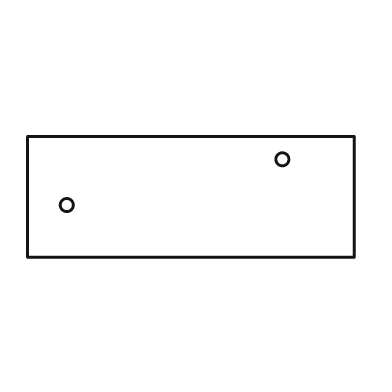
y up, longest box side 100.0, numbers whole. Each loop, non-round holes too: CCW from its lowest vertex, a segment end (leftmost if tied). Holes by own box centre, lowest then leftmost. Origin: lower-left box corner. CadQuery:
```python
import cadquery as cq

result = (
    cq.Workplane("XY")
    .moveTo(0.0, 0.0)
    .lineTo(100.0, 0.0)
    .lineTo(100.0, 37.0)
    .lineTo(0.0, 37.0)
    .close()
    .moveTo(12.0, 16.0)
    .circle(2.0)
    .moveTo(78.0, 30.0)
    .circle(2.0)
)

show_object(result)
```